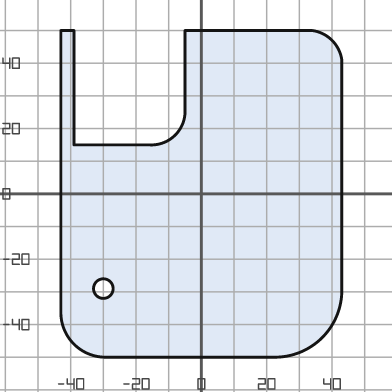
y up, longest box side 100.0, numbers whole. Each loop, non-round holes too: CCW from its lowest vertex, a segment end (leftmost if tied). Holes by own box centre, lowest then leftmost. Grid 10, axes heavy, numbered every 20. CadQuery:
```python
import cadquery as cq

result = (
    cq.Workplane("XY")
    .moveTo(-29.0, -50.0)
    .lineTo(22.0, -50.0)
    .threePointArc((37.0, -44.0), (43.0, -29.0))
    .lineTo(43.0, 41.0)
    .threePointArc((40.0, 47.0), (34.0, 50.0))
    .lineTo(-5.0, 50.0)
    .lineTo(-5.0, 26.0)
    .threePointArc((-8.0, 18.0), (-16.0, 15.0))
    .lineTo(-39.0, 15.0)
    .lineTo(-39.0, 50.0)
    .lineTo(-43.0, 50.0)
    .lineTo(-43.0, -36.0)
    .threePointArc((-39.0, -46.0), (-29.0, -50.0))
    .close()
    .moveTo(-30.0, -29.0)
    .circle(3.0)
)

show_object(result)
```